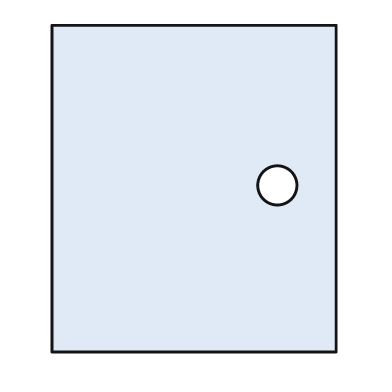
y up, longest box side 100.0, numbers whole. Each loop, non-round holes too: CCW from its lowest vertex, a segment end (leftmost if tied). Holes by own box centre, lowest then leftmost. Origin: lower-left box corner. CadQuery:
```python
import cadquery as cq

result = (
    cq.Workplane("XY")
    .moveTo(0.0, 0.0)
    .lineTo(87.0, 0.0)
    .lineTo(87.0, 100.0)
    .lineTo(0.0, 100.0)
    .close()
    .moveTo(69.0, 51.0)
    .circle(6.0)
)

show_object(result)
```